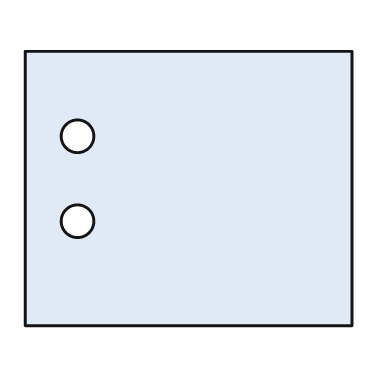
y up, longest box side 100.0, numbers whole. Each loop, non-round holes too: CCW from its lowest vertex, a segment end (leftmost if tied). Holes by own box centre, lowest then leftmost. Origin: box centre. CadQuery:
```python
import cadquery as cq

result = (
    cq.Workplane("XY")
    .moveTo(-50.0, -42.0)
    .lineTo(50.0, -42.0)
    .lineTo(50.0, 42.0)
    .lineTo(-50.0, 42.0)
    .close()
    .moveTo(-34.0, -10.0)
    .circle(5.0)
    .moveTo(-34.0, 16.0)
    .circle(5.0)
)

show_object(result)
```